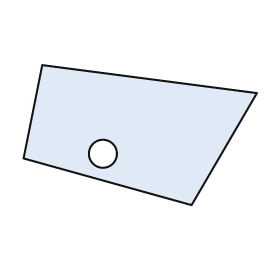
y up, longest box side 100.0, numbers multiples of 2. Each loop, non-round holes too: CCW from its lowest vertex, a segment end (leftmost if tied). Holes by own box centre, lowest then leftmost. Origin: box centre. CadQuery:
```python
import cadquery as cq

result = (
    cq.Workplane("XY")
    .moveTo(22.0, -30.0)
    .lineTo(50.0, 18.0)
    .lineTo(-42.0, 30.0)
    .lineTo(-50.0, -10.0)
    .close()
    .moveTo(-16.0, -8.0)
    .circle(6.0)
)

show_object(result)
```